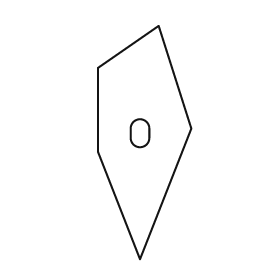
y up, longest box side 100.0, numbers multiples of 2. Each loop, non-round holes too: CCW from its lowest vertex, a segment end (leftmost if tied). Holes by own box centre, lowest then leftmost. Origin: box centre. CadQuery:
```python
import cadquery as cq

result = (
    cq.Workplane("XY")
    .moveTo(-2.0, -50.0)
    .lineTo(20.0, 6.0)
    .lineTo(6.0, 50.0)
    .lineTo(-20.0, 32.0)
    .lineTo(-20.0, -4.0)
    .close()
    .moveTo(-6.0, 2.0)
    .threePointArc((-2.0, -2.0), (2.0, 2.0))
    .lineTo(2.0, 6.0)
    .threePointArc((-2.0, 10.0), (-6.0, 6.0))
    .close()
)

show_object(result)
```